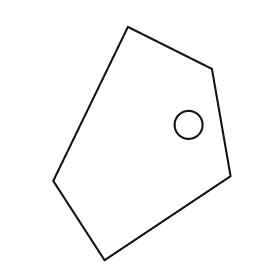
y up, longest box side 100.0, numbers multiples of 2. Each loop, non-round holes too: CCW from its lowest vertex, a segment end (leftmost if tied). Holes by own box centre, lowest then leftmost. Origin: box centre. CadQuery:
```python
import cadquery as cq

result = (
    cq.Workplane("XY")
    .moveTo(-16.0, -50.0)
    .lineTo(38.0, -14.0)
    .lineTo(30.0, 32.0)
    .lineTo(-6.0, 50.0)
    .lineTo(-38.0, -16.0)
    .close()
    .moveTo(20.0, 8.0)
    .circle(6.0)
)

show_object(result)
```